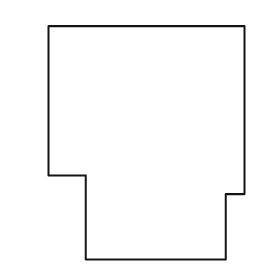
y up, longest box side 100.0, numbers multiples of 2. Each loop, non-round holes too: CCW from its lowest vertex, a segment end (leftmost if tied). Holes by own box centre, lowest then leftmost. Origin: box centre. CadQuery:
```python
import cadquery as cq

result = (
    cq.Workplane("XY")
    .moveTo(-26.0, -50.0)
    .lineTo(34.0, -50.0)
    .lineTo(34.0, -22.0)
    .lineTo(42.0, -22.0)
    .lineTo(42.0, 50.0)
    .lineTo(-42.0, 50.0)
    .lineTo(-42.0, -14.0)
    .lineTo(-26.0, -14.0)
    .close()
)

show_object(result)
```